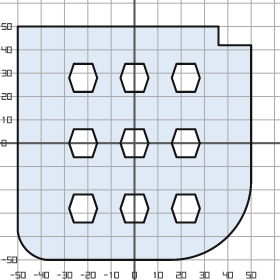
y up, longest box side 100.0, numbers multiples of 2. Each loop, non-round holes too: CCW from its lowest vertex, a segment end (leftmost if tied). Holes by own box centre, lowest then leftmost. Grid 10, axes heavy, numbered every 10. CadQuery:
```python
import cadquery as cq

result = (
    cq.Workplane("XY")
    .moveTo(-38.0, -50.0)
    .lineTo(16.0, -50.0)
    .threePointArc((40.0, -40.0), (50.0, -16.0))
    .lineTo(50.0, 42.0)
    .lineTo(36.0, 42.0)
    .lineTo(36.0, 50.0)
    .lineTo(-50.0, 50.0)
    .lineTo(-50.0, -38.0)
    .threePointArc((-46.0, -46.0), (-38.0, -50.0))
    .close()
    .moveTo(-26.0, -34.0)
    .lineTo(-18.0, -34.0)
    .lineTo(-16.0, -28.0)
    .lineTo(-18.0, -22.0)
    .lineTo(-26.0, -22.0)
    .lineTo(-28.0, -28.0)
    .close()
    .moveTo(-4.0, -34.0)
    .lineTo(4.0, -34.0)
    .lineTo(6.0, -28.0)
    .lineTo(4.0, -22.0)
    .lineTo(-4.0, -22.0)
    .lineTo(-6.0, -28.0)
    .close()
    .moveTo(18.0, -34.0)
    .lineTo(26.0, -34.0)
    .lineTo(28.0, -28.0)
    .lineTo(26.0, -22.0)
    .lineTo(18.0, -22.0)
    .lineTo(16.0, -28.0)
    .close()
    .moveTo(-26.0, -6.0)
    .lineTo(-18.0, -6.0)
    .lineTo(-16.0, 0.0)
    .lineTo(-18.0, 6.0)
    .lineTo(-26.0, 6.0)
    .lineTo(-28.0, 0.0)
    .close()
    .moveTo(-4.0, -6.0)
    .lineTo(4.0, -6.0)
    .lineTo(6.0, 0.0)
    .lineTo(4.0, 6.0)
    .lineTo(-4.0, 6.0)
    .lineTo(-6.0, 0.0)
    .close()
    .moveTo(18.0, -6.0)
    .lineTo(26.0, -6.0)
    .lineTo(28.0, 0.0)
    .lineTo(26.0, 6.0)
    .lineTo(18.0, 6.0)
    .lineTo(16.0, 0.0)
    .close()
    .moveTo(-26.0, 22.0)
    .lineTo(-18.0, 22.0)
    .lineTo(-16.0, 28.0)
    .lineTo(-18.0, 34.0)
    .lineTo(-26.0, 34.0)
    .lineTo(-28.0, 28.0)
    .close()
    .moveTo(-4.0, 22.0)
    .lineTo(4.0, 22.0)
    .lineTo(6.0, 28.0)
    .lineTo(4.0, 34.0)
    .lineTo(-4.0, 34.0)
    .lineTo(-6.0, 28.0)
    .close()
    .moveTo(18.0, 22.0)
    .lineTo(26.0, 22.0)
    .lineTo(28.0, 28.0)
    .lineTo(26.0, 34.0)
    .lineTo(18.0, 34.0)
    .lineTo(16.0, 28.0)
    .close()
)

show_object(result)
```